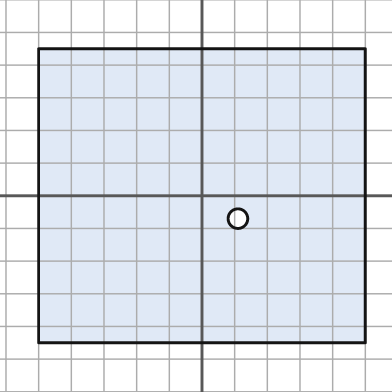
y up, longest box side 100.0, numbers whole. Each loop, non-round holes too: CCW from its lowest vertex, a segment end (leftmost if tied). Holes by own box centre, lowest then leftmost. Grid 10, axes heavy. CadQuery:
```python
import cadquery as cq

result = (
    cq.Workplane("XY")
    .moveTo(-50.0, -45.0)
    .lineTo(50.0, -45.0)
    .lineTo(50.0, 45.0)
    .lineTo(-50.0, 45.0)
    .close()
    .moveTo(11.0, -7.0)
    .circle(3.0)
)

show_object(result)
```